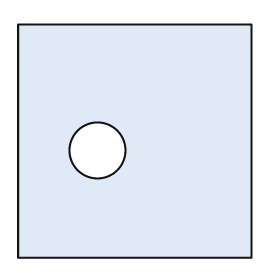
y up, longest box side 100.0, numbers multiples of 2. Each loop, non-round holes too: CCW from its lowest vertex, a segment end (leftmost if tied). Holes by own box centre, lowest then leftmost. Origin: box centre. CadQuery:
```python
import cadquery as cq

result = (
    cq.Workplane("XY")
    .moveTo(-50.0, -50.0)
    .lineTo(50.0, -50.0)
    .lineTo(50.0, 50.0)
    .lineTo(-50.0, 50.0)
    .close()
    .moveTo(-16.0, -4.0)
    .circle(12.0)
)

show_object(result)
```